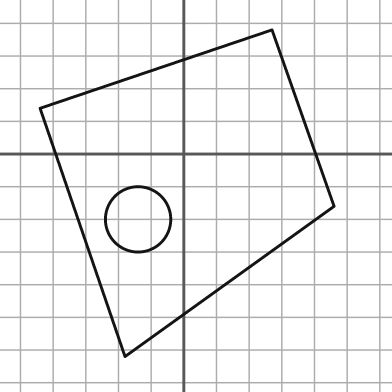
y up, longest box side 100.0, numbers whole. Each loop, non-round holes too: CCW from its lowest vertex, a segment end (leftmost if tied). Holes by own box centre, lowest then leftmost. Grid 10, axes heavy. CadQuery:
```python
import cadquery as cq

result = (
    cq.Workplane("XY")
    .moveTo(-18.0, -62.0)
    .lineTo(46.0, -16.0)
    .lineTo(27.0, 38.0)
    .lineTo(-44.0, 14.0)
    .close()
    .moveTo(-14.0, -20.0)
    .circle(10.0)
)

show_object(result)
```